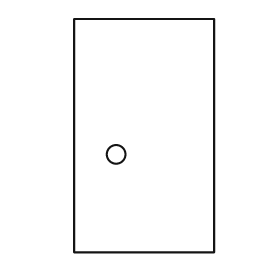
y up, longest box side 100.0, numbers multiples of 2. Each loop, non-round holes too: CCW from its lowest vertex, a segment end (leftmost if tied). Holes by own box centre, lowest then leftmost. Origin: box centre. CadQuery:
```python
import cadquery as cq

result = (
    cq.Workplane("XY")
    .moveTo(-30.0, -50.0)
    .lineTo(30.0, -50.0)
    .lineTo(30.0, 50.0)
    .lineTo(-30.0, 50.0)
    .close()
    .moveTo(-12.0, -8.0)
    .circle(4.0)
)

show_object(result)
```